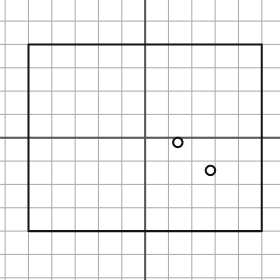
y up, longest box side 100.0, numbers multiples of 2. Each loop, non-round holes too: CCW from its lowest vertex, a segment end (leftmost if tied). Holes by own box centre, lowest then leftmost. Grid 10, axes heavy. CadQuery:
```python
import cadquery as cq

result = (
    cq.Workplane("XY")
    .moveTo(-50.0, -40.0)
    .lineTo(50.0, -40.0)
    .lineTo(50.0, 40.0)
    .lineTo(-50.0, 40.0)
    .close()
    .moveTo(28.0, -14.0)
    .circle(2.0)
    .moveTo(14.0, -2.0)
    .circle(2.0)
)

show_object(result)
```